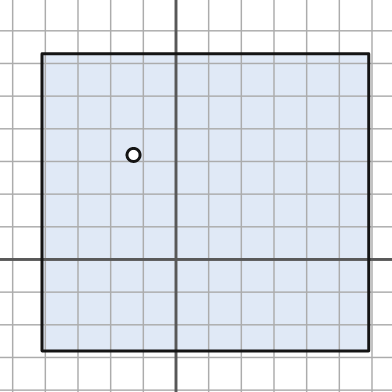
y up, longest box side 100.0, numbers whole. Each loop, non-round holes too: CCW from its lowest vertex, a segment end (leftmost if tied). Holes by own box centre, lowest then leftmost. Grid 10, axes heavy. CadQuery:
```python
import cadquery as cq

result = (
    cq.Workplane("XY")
    .moveTo(-41.0, -28.0)
    .lineTo(59.0, -28.0)
    .lineTo(59.0, 63.0)
    .lineTo(-41.0, 63.0)
    .close()
    .moveTo(-13.0, 32.0)
    .circle(2.0)
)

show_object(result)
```